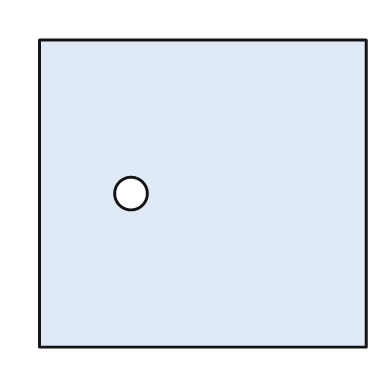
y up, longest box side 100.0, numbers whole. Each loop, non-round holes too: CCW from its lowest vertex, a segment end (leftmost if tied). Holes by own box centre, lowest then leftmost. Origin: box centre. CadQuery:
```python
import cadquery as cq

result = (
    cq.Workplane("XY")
    .moveTo(-50.0, -47.0)
    .lineTo(50.0, -47.0)
    .lineTo(50.0, 47.0)
    .lineTo(-50.0, 47.0)
    .close()
    .moveTo(-22.0, 0.0)
    .circle(5.0)
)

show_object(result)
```